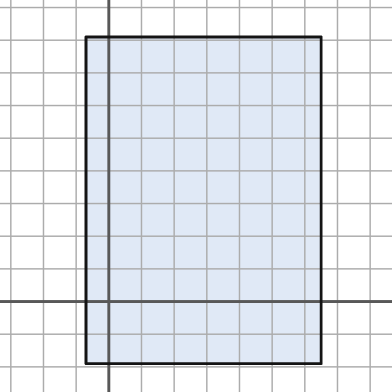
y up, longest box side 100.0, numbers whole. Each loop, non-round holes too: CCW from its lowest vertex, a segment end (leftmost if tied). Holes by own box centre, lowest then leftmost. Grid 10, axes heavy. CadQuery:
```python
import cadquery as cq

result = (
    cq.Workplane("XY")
    .moveTo(-7.0, -19.0)
    .lineTo(65.0, -19.0)
    .lineTo(65.0, 81.0)
    .lineTo(-7.0, 81.0)
    .close()
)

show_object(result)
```